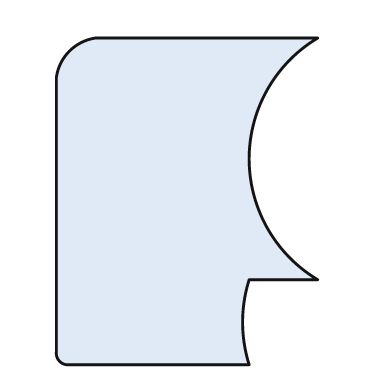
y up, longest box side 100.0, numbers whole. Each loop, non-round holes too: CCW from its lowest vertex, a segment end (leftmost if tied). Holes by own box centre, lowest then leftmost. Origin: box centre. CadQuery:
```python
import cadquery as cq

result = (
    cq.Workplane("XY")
    .moveTo(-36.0, -50.0)
    .lineTo(19.0, -50.0)
    .threePointArc((17.0, -37.0), (19.0, -24.0))
    .lineTo(40.0, -24.0)
    .threePointArc((19.0, 13.0), (40.0, 50.0))
    .lineTo(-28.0, 50.0)
    .threePointArc((-36.0, 46.0), (-40.0, 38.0))
    .lineTo(-40.0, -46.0)
    .threePointArc((-39.0, -49.0), (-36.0, -50.0))
    .close()
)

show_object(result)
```